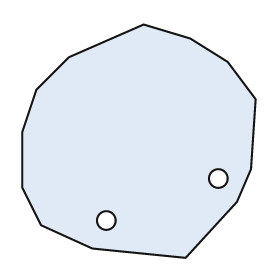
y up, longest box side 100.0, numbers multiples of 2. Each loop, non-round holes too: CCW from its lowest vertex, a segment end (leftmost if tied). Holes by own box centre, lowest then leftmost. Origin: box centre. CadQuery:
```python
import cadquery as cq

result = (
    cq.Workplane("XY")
    .moveTo(20.0, -50.0)
    .lineTo(42.0, -26.0)
    .lineTo(48.0, -12.0)
    .lineTo(50.0, 18.0)
    .lineTo(38.0, 34.0)
    .lineTo(22.0, 44.0)
    .lineTo(2.0, 50.0)
    .lineTo(-30.0, 36.0)
    .lineTo(-44.0, 22.0)
    .lineTo(-50.0, 4.0)
    .lineTo(-50.0, -20.0)
    .lineTo(-42.0, -36.0)
    .lineTo(-20.0, -46.0)
    .close()
    .moveTo(-14.0, -34.0)
    .circle(4.0)
    .moveTo(34.0, -16.0)
    .circle(4.0)
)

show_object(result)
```